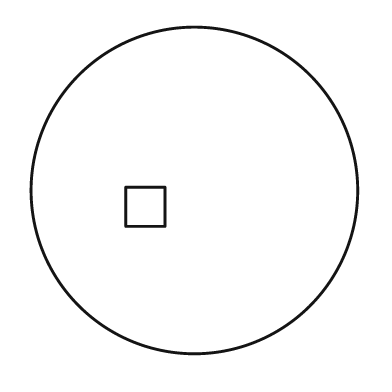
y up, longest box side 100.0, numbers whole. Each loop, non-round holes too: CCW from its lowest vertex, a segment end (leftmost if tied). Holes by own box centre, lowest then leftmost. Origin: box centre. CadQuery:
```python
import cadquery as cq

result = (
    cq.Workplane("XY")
    .moveTo(0.0, 0.0)
    .circle(50.0)
    .moveTo(-21.0, -11.0)
    .lineTo(-9.0, -11.0)
    .lineTo(-9.0, 1.0)
    .lineTo(-21.0, 1.0)
    .close()
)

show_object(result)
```